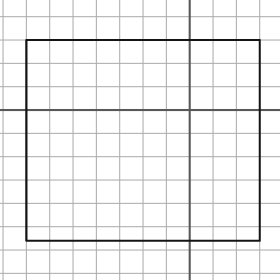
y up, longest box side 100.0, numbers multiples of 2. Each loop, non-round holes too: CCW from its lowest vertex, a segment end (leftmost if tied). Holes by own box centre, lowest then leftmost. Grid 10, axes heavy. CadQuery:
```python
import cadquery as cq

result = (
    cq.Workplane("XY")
    .moveTo(-70.0, -56.0)
    .lineTo(30.0, -56.0)
    .lineTo(30.0, 30.0)
    .lineTo(-70.0, 30.0)
    .close()
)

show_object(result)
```